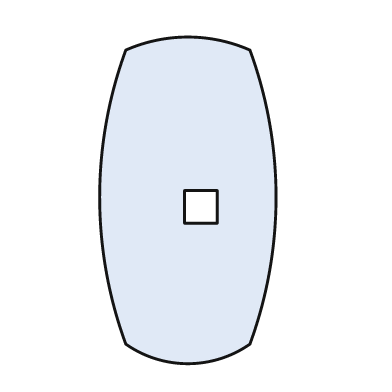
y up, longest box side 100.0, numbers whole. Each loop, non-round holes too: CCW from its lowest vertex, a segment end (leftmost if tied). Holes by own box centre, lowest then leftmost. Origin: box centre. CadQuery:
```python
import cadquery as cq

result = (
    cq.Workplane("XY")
    .moveTo(-19.0, -44.0)
    .threePointArc((0.0, -50.0), (19.0, -44.0))
    .threePointArc((27.0, 1.0), (19.0, 46.0))
    .threePointArc((0.0, 50.0), (-19.0, 46.0))
    .threePointArc((-27.0, 1.0), (-19.0, -44.0))
    .close()
    .moveTo(-1.0, -7.0)
    .lineTo(9.0, -7.0)
    .lineTo(9.0, 3.0)
    .lineTo(-1.0, 3.0)
    .close()
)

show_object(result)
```